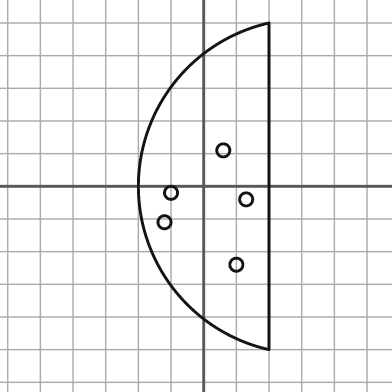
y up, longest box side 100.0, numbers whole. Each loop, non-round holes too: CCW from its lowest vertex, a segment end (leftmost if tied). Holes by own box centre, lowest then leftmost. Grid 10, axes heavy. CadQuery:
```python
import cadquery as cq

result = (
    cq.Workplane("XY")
    .moveTo(20.0, -50.0)
    .lineTo(20.0, 50.0)
    .threePointArc((-20.0, 0.0), (20.0, -50.0))
    .close()
    .moveTo(10.0, -24.0)
    .circle(2.0)
    .moveTo(-12.0, -11.0)
    .circle(2.0)
    .moveTo(13.0, -4.0)
    .circle(2.0)
    .moveTo(-10.0, -2.0)
    .circle(2.0)
    .moveTo(6.0, 11.0)
    .circle(2.0)
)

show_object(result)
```